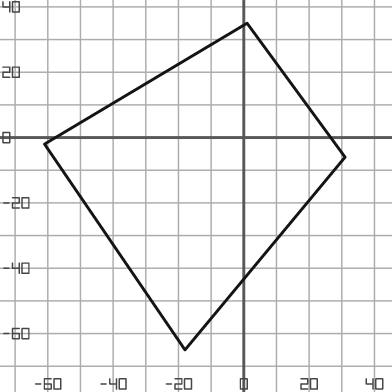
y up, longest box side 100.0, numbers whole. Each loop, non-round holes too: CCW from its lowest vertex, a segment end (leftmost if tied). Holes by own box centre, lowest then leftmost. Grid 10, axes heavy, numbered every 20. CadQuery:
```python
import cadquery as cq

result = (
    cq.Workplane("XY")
    .moveTo(-18.0, -65.0)
    .lineTo(31.0, -6.0)
    .lineTo(1.0, 35.0)
    .lineTo(-61.0, -2.0)
    .close()
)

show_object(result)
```